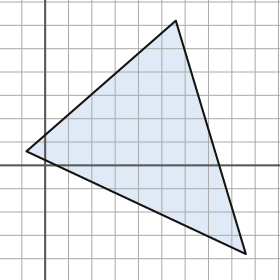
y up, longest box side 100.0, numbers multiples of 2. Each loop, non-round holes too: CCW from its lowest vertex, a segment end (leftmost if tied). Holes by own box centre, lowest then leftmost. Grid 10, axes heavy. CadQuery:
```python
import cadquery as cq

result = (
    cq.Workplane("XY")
    .moveTo(86.0, -38.0)
    .lineTo(56.0, 62.0)
    .lineTo(-8.0, 6.0)
    .close()
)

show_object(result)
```